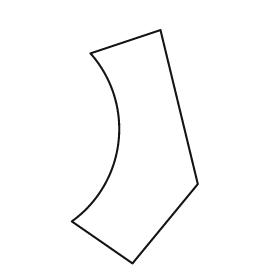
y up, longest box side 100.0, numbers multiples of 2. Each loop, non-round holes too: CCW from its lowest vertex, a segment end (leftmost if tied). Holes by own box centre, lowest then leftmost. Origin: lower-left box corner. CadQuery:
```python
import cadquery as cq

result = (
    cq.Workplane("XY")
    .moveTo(26.0, 0.0)
    .lineTo(54.0, 34.0)
    .lineTo(38.0, 100.0)
    .lineTo(8.0, 90.0)
    .threePointArc((20.0, 52.0), (0.0, 18.0))
    .close()
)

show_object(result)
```